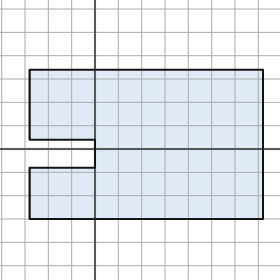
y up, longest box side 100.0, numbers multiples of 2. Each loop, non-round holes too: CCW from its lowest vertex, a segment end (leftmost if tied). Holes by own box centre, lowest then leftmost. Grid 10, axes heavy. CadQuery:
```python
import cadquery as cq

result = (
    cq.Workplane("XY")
    .moveTo(-28.0, -30.0)
    .lineTo(72.0, -30.0)
    .lineTo(72.0, 34.0)
    .lineTo(-28.0, 34.0)
    .lineTo(-28.0, 4.0)
    .lineTo(0.0, 4.0)
    .lineTo(0.0, -8.0)
    .lineTo(-28.0, -8.0)
    .close()
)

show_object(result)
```